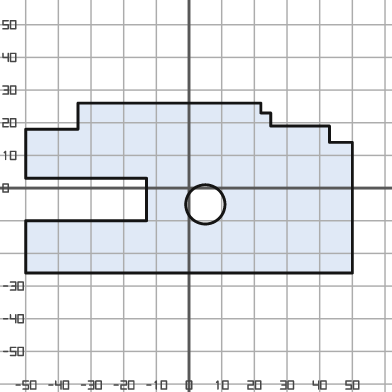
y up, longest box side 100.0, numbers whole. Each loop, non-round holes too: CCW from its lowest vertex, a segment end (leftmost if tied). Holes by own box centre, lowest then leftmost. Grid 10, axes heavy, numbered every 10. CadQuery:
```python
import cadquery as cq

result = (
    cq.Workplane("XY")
    .moveTo(-50.0, -26.0)
    .lineTo(50.0, -26.0)
    .lineTo(50.0, 14.0)
    .lineTo(43.0, 14.0)
    .lineTo(43.0, 19.0)
    .lineTo(25.0, 19.0)
    .lineTo(25.0, 23.0)
    .lineTo(22.0, 23.0)
    .lineTo(22.0, 26.0)
    .lineTo(-34.0, 26.0)
    .lineTo(-34.0, 18.0)
    .lineTo(-50.0, 18.0)
    .lineTo(-50.0, 3.0)
    .lineTo(-13.0, 3.0)
    .lineTo(-13.0, -10.0)
    .lineTo(-50.0, -10.0)
    .close()
    .moveTo(5.0, -5.0)
    .circle(6.0)
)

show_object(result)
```